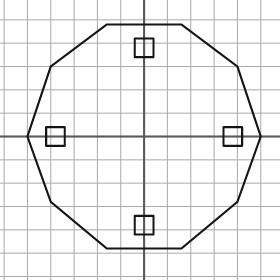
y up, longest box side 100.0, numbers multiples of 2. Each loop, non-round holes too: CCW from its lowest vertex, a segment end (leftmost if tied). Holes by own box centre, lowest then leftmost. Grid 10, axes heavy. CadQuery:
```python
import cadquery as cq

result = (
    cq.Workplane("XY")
    .moveTo(-16.0, -48.0)
    .lineTo(16.0, -48.0)
    .lineTo(40.0, -28.0)
    .lineTo(50.0, 0.0)
    .lineTo(40.0, 30.0)
    .lineTo(16.0, 48.0)
    .lineTo(-16.0, 48.0)
    .lineTo(-40.0, 30.0)
    .lineTo(-50.0, 0.0)
    .lineTo(-40.0, -28.0)
    .close()
    .moveTo(-4.0, -42.0)
    .lineTo(4.0, -42.0)
    .lineTo(4.0, -34.0)
    .lineTo(-4.0, -34.0)
    .close()
    .moveTo(-42.0, -4.0)
    .lineTo(-34.0, -4.0)
    .lineTo(-34.0, 4.0)
    .lineTo(-42.0, 4.0)
    .close()
    .moveTo(34.0, -4.0)
    .lineTo(42.0, -4.0)
    .lineTo(42.0, 4.0)
    .lineTo(34.0, 4.0)
    .close()
    .moveTo(-4.0, 34.0)
    .lineTo(4.0, 34.0)
    .lineTo(4.0, 42.0)
    .lineTo(-4.0, 42.0)
    .close()
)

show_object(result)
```